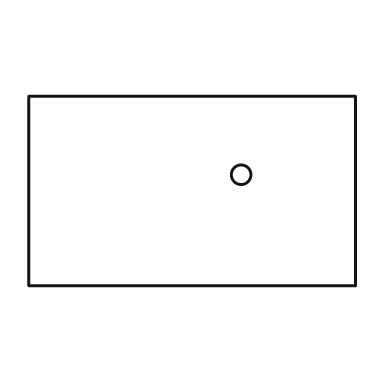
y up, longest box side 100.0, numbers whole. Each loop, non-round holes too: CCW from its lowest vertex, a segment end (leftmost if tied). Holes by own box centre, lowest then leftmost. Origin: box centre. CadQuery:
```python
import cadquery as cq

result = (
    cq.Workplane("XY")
    .moveTo(-50.0, -29.0)
    .lineTo(50.0, -29.0)
    .lineTo(50.0, 29.0)
    .lineTo(-50.0, 29.0)
    .close()
    .moveTo(15.0, 5.0)
    .circle(3.0)
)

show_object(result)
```